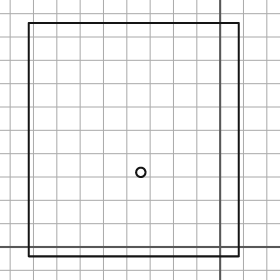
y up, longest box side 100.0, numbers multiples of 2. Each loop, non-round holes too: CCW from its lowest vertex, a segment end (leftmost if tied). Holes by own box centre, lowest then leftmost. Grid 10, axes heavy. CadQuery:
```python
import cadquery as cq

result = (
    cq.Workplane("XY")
    .moveTo(-82.0, -4.0)
    .lineTo(8.0, -4.0)
    .lineTo(8.0, 96.0)
    .lineTo(-82.0, 96.0)
    .close()
    .moveTo(-34.0, 32.0)
    .circle(2.0)
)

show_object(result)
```